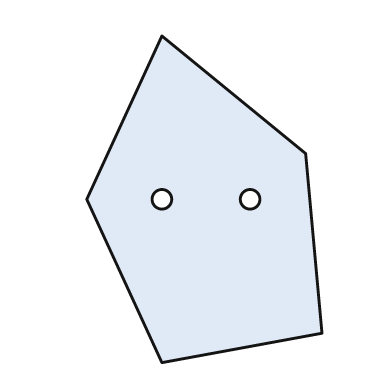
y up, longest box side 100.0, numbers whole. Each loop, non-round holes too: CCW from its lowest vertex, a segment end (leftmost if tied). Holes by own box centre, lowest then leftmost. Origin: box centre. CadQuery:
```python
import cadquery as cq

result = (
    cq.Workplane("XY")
    .moveTo(-13.0, -50.0)
    .lineTo(36.0, -41.0)
    .lineTo(31.0, 14.0)
    .lineTo(-13.0, 50.0)
    .lineTo(-36.0, 0.0)
    .close()
    .moveTo(-13.0, 0.0)
    .circle(3.0)
    .moveTo(14.0, 0.0)
    .circle(3.0)
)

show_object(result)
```